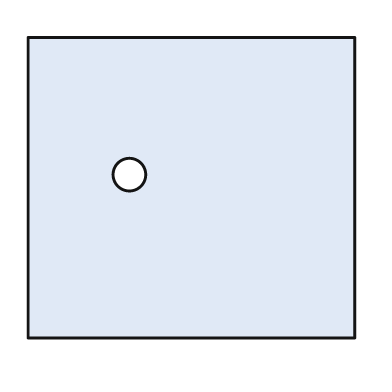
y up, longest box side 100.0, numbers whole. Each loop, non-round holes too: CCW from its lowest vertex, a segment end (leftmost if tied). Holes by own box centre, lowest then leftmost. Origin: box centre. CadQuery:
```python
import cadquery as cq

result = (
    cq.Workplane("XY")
    .moveTo(-50.0, -46.0)
    .lineTo(50.0, -46.0)
    .lineTo(50.0, 46.0)
    .lineTo(-50.0, 46.0)
    .close()
    .moveTo(-19.0, 4.0)
    .circle(5.0)
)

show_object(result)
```